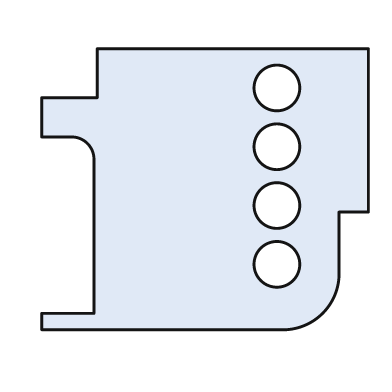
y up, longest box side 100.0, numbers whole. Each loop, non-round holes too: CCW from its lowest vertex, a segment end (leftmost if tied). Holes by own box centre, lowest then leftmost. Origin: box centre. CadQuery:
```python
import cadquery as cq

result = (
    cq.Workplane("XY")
    .moveTo(-50.0, -43.0)
    .lineTo(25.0, -43.0)
    .threePointArc((36.0, -38.0), (41.0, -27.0))
    .lineTo(41.0, -7.0)
    .lineTo(50.0, -7.0)
    .lineTo(50.0, 43.0)
    .lineTo(-33.0, 43.0)
    .lineTo(-33.0, 28.0)
    .lineTo(-50.0, 28.0)
    .lineTo(-50.0, 16.0)
    .lineTo(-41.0, 16.0)
    .threePointArc((-36.0, 14.0), (-34.0, 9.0))
    .lineTo(-34.0, -38.0)
    .lineTo(-50.0, -38.0)
    .close()
    .moveTo(22.0, -23.0)
    .circle(7.0)
    .moveTo(22.0, -5.0)
    .circle(7.0)
    .moveTo(22.0, 13.0)
    .circle(7.0)
    .moveTo(22.0, 31.0)
    .circle(7.0)
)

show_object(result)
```